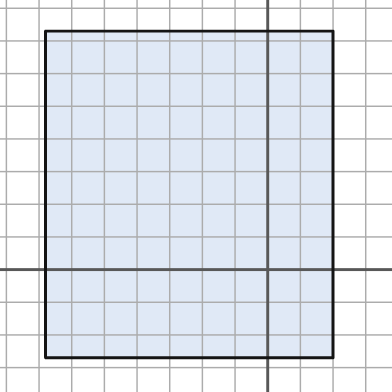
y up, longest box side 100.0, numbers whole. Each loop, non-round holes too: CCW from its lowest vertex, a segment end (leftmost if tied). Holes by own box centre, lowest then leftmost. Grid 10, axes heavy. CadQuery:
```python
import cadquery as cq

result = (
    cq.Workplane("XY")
    .moveTo(-68.0, -27.0)
    .lineTo(20.0, -27.0)
    .lineTo(20.0, 73.0)
    .lineTo(-68.0, 73.0)
    .close()
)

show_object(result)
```